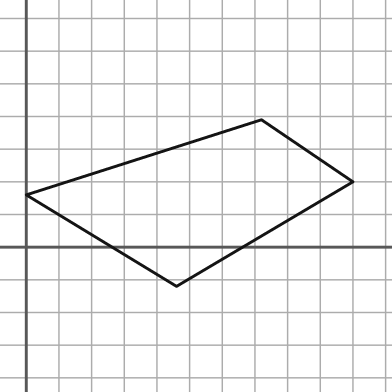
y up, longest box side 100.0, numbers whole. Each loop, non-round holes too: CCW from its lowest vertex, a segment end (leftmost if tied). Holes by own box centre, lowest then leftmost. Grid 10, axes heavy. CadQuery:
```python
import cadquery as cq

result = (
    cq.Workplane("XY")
    .moveTo(46.0, -12.0)
    .lineTo(100.0, 20.0)
    .lineTo(72.0, 39.0)
    .lineTo(0.0, 16.0)
    .close()
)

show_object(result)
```